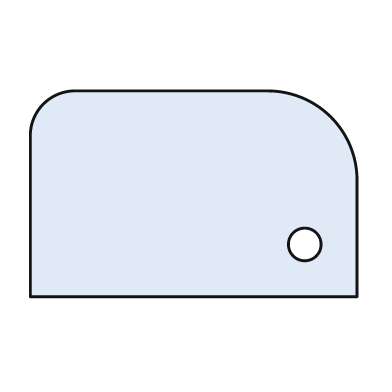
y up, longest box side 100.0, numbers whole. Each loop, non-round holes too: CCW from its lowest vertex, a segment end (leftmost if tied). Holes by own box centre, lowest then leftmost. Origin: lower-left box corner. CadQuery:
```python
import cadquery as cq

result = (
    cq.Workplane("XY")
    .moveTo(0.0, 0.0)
    .lineTo(100.0, 0.0)
    .lineTo(100.0, 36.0)
    .threePointArc((92.0, 55.0), (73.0, 63.0))
    .lineTo(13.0, 63.0)
    .threePointArc((4.0, 59.0), (0.0, 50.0))
    .close()
    .moveTo(84.0, 16.0)
    .circle(5.0)
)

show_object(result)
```